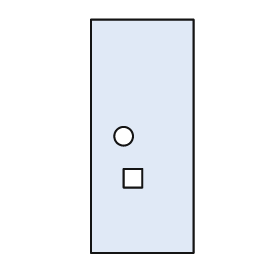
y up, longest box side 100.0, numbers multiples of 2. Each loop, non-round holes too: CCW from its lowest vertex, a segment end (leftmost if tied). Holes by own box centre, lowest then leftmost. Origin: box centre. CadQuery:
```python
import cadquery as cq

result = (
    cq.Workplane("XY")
    .moveTo(-22.0, -50.0)
    .lineTo(22.0, -50.0)
    .lineTo(22.0, 50.0)
    .lineTo(-22.0, 50.0)
    .close()
    .moveTo(-8.0, -22.0)
    .lineTo(0.0, -22.0)
    .lineTo(0.0, -14.0)
    .lineTo(-8.0, -14.0)
    .close()
    .moveTo(-8.0, 0.0)
    .circle(4.0)
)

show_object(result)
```